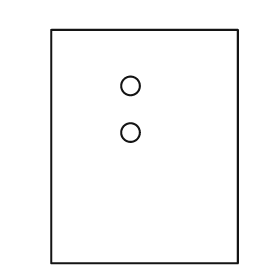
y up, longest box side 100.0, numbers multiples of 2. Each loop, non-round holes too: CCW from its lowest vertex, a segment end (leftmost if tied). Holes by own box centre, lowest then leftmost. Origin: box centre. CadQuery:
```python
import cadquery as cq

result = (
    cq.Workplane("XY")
    .moveTo(-40.0, -50.0)
    .lineTo(40.0, -50.0)
    .lineTo(40.0, 50.0)
    .lineTo(-40.0, 50.0)
    .close()
    .moveTo(-6.0, 6.0)
    .circle(4.0)
    .moveTo(-6.0, 26.0)
    .circle(4.0)
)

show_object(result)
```